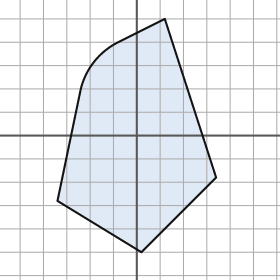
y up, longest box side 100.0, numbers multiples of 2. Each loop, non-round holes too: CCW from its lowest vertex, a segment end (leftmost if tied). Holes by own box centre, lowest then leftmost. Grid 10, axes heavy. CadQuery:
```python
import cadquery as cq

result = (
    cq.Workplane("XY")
    .moveTo(2.0, -50.0)
    .lineTo(34.0, -18.0)
    .lineTo(12.0, 50.0)
    .lineTo(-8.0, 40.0)
    .threePointArc((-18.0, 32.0), (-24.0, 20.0))
    .lineTo(-34.0, -28.0)
    .close()
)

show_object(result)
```